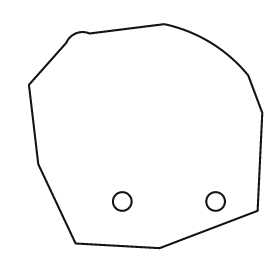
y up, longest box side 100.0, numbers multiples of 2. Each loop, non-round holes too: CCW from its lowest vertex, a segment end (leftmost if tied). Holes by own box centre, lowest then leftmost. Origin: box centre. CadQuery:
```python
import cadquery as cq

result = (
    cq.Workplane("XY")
    .moveTo(6.0, -48.0)
    .lineTo(48.0, -32.0)
    .lineTo(50.0, 10.0)
    .lineTo(44.0, 26.0)
    .threePointArc((28.0, 40.0), (8.0, 48.0))
    .lineTo(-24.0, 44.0)
    .threePointArc((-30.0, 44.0), (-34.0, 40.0))
    .lineTo(-50.0, 22.0)
    .lineTo(-46.0, -12.0)
    .lineTo(-30.0, -46.0)
    .close()
    .moveTo(-10.0, -28.0)
    .circle(4.0)
    .moveTo(30.0, -28.0)
    .circle(4.0)
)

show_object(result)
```